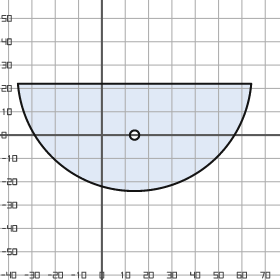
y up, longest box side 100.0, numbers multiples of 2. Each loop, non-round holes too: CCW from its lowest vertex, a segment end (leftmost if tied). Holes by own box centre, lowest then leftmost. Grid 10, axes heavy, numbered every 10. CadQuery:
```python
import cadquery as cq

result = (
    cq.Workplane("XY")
    .moveTo(-36.0, 22.0)
    .threePointArc((14.0, -24.0), (64.0, 22.0))
    .close()
    .moveTo(14.0, 0.0)
    .circle(2.0)
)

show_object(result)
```